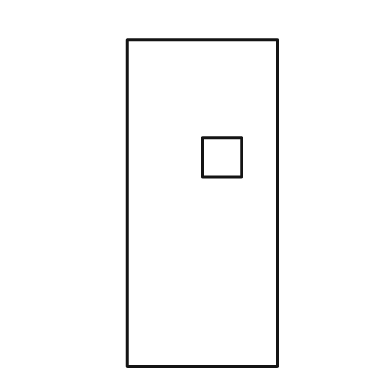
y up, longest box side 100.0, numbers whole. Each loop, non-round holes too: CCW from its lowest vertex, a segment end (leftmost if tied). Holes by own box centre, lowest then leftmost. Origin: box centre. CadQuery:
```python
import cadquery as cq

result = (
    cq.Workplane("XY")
    .moveTo(-23.0, -50.0)
    .lineTo(23.0, -50.0)
    .lineTo(23.0, 50.0)
    .lineTo(-23.0, 50.0)
    .close()
    .moveTo(0.0, 8.0)
    .lineTo(12.0, 8.0)
    .lineTo(12.0, 20.0)
    .lineTo(0.0, 20.0)
    .close()
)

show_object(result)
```